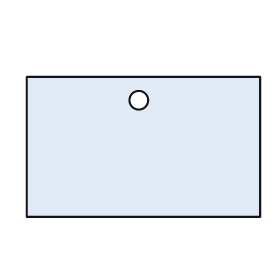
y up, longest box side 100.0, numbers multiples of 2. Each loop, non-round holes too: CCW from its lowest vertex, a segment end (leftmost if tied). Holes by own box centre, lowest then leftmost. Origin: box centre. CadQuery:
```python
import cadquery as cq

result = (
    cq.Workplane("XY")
    .moveTo(-50.0, -30.0)
    .lineTo(50.0, -30.0)
    .lineTo(50.0, 30.0)
    .lineTo(-50.0, 30.0)
    .close()
    .moveTo(-2.0, 20.0)
    .circle(4.0)
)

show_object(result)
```